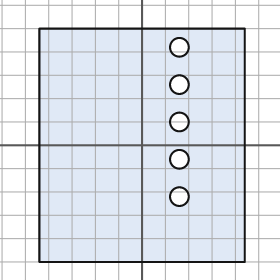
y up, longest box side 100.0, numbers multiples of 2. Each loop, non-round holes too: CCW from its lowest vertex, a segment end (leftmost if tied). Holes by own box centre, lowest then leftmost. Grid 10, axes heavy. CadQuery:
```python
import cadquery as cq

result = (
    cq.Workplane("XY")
    .moveTo(-44.0, -50.0)
    .lineTo(44.0, -50.0)
    .lineTo(44.0, 50.0)
    .lineTo(-44.0, 50.0)
    .close()
    .moveTo(16.0, -22.0)
    .circle(4.0)
    .moveTo(16.0, -6.0)
    .circle(4.0)
    .moveTo(16.0, 10.0)
    .circle(4.0)
    .moveTo(16.0, 26.0)
    .circle(4.0)
    .moveTo(16.0, 42.0)
    .circle(4.0)
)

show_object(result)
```